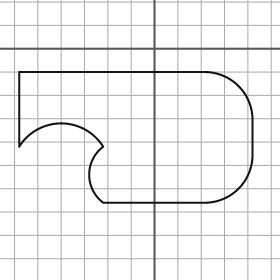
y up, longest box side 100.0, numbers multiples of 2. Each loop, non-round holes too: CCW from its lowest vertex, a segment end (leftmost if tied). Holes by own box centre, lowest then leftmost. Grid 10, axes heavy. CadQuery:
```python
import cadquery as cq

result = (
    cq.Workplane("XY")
    .moveTo(-22.0, -66.0)
    .lineTo(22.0, -66.0)
    .threePointArc((36.0, -60.0), (42.0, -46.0))
    .lineTo(42.0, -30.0)
    .threePointArc((36.0, -16.0), (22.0, -10.0))
    .lineTo(-58.0, -10.0)
    .lineTo(-58.0, -42.0)
    .threePointArc((-40.0, -32.0), (-22.0, -42.0))
    .threePointArc((-28.0, -54.0), (-22.0, -66.0))
    .close()
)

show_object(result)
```